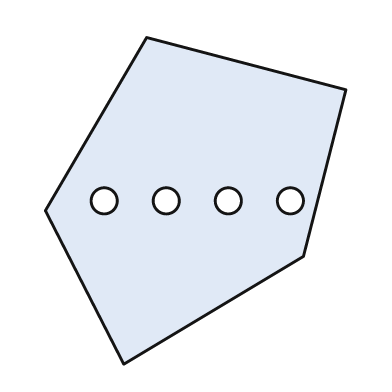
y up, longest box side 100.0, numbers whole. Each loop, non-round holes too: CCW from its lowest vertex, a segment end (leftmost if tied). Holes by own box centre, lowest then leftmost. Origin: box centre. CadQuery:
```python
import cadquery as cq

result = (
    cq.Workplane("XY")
    .moveTo(-22.0, -50.0)
    .lineTo(33.0, -17.0)
    .lineTo(46.0, 34.0)
    .lineTo(-15.0, 50.0)
    .lineTo(-46.0, -3.0)
    .close()
    .moveTo(-28.0, 0.0)
    .circle(4.0)
    .moveTo(-9.0, 0.0)
    .circle(4.0)
    .moveTo(10.0, 0.0)
    .circle(4.0)
    .moveTo(29.0, 0.0)
    .circle(4.0)
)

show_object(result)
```